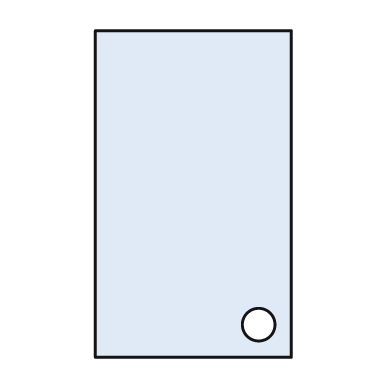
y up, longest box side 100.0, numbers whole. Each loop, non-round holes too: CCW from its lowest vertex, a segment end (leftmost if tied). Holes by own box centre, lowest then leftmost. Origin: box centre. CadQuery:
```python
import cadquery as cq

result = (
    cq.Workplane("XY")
    .moveTo(-30.0, -50.0)
    .lineTo(30.0, -50.0)
    .lineTo(30.0, 50.0)
    .lineTo(-30.0, 50.0)
    .close()
    .moveTo(20.0, -40.0)
    .circle(5.0)
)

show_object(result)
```